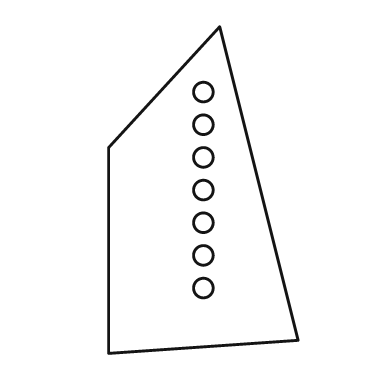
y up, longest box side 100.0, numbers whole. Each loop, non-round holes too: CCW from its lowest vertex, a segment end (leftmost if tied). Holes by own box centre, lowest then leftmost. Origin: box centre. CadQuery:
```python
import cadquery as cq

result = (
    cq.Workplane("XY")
    .moveTo(-29.0, -50.0)
    .lineTo(29.0, -46.0)
    .lineTo(5.0, 50.0)
    .lineTo(-29.0, 13.0)
    .close()
    .moveTo(0.0, -30.0)
    .circle(3.0)
    .moveTo(0.0, -20.0)
    .circle(3.0)
    .moveTo(0.0, -10.0)
    .circle(3.0)
    .moveTo(0.0, 0.0)
    .circle(3.0)
    .moveTo(0.0, 10.0)
    .circle(3.0)
    .moveTo(0.0, 20.0)
    .circle(3.0)
    .moveTo(0.0, 30.0)
    .circle(3.0)
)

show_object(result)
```